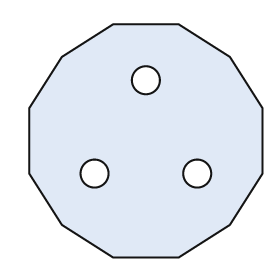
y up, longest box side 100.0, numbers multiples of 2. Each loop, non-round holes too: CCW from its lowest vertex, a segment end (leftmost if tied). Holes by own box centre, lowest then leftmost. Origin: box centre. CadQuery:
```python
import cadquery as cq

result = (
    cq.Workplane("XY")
    .moveTo(-14.0, -50.0)
    .lineTo(14.0, -50.0)
    .lineTo(36.0, -36.0)
    .lineTo(50.0, -14.0)
    .lineTo(50.0, 14.0)
    .lineTo(36.0, 36.0)
    .lineTo(14.0, 50.0)
    .lineTo(-14.0, 50.0)
    .lineTo(-36.0, 36.0)
    .lineTo(-50.0, 14.0)
    .lineTo(-50.0, -14.0)
    .lineTo(-36.0, -36.0)
    .close()
    .moveTo(-22.0, -14.0)
    .circle(6.0)
    .moveTo(22.0, -14.0)
    .circle(6.0)
    .moveTo(0.0, 26.0)
    .circle(6.0)
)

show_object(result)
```